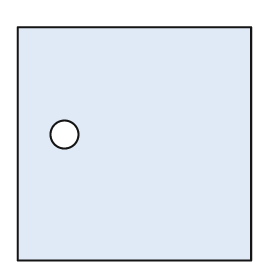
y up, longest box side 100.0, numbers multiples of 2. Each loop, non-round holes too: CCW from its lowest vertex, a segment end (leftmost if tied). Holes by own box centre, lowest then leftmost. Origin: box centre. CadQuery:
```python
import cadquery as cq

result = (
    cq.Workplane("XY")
    .moveTo(-50.0, -50.0)
    .lineTo(50.0, -50.0)
    .lineTo(50.0, 50.0)
    .lineTo(-50.0, 50.0)
    .close()
    .moveTo(-30.0, 4.0)
    .circle(6.0)
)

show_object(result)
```